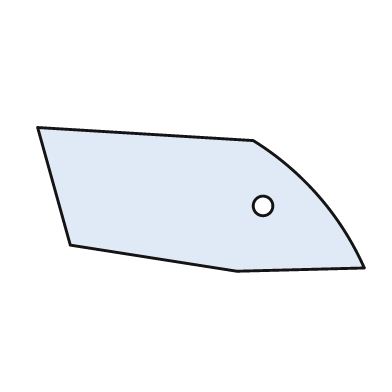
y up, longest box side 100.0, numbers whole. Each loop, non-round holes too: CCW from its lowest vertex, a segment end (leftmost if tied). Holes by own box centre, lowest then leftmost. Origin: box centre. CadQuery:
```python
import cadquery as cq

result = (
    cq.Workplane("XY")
    .moveTo(11.0, -22.0)
    .lineTo(50.0, -21.0)
    .threePointArc((36.0, 1.0), (16.0, 18.0))
    .lineTo(-50.0, 22.0)
    .lineTo(-40.0, -14.0)
    .close()
    .moveTo(19.0, -2.0)
    .circle(3.0)
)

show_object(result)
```